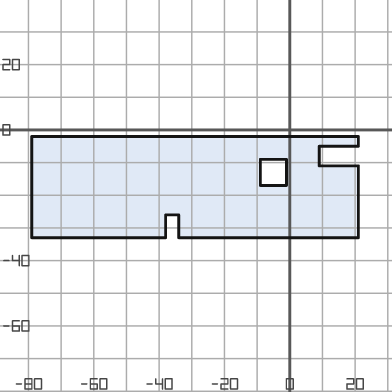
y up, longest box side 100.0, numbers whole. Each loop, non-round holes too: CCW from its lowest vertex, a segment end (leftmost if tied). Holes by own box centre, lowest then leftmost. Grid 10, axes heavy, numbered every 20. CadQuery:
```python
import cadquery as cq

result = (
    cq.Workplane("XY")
    .moveTo(-79.0, -33.0)
    .lineTo(-38.0, -33.0)
    .lineTo(-38.0, -26.0)
    .lineTo(-34.0, -26.0)
    .lineTo(-34.0, -33.0)
    .lineTo(21.0, -33.0)
    .lineTo(21.0, -11.0)
    .lineTo(9.0, -11.0)
    .lineTo(9.0, -5.0)
    .lineTo(21.0, -5.0)
    .lineTo(21.0, -2.0)
    .lineTo(-79.0, -2.0)
    .close()
    .moveTo(-9.0, -17.0)
    .lineTo(-1.0, -17.0)
    .lineTo(-1.0, -9.0)
    .lineTo(-9.0, -9.0)
    .close()
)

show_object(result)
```